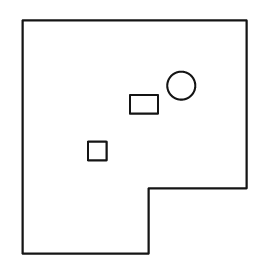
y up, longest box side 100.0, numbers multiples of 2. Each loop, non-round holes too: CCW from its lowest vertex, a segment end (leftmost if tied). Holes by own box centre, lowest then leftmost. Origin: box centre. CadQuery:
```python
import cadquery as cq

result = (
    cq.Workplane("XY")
    .moveTo(-48.0, -50.0)
    .lineTo(6.0, -50.0)
    .lineTo(6.0, -22.0)
    .lineTo(48.0, -22.0)
    .lineTo(48.0, 50.0)
    .lineTo(-48.0, 50.0)
    .close()
    .moveTo(-20.0, -10.0)
    .lineTo(-12.0, -10.0)
    .lineTo(-12.0, -2.0)
    .lineTo(-20.0, -2.0)
    .close()
    .moveTo(-2.0, 10.0)
    .lineTo(10.0, 10.0)
    .lineTo(10.0, 18.0)
    .lineTo(-2.0, 18.0)
    .close()
    .moveTo(20.0, 22.0)
    .circle(6.0)
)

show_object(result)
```